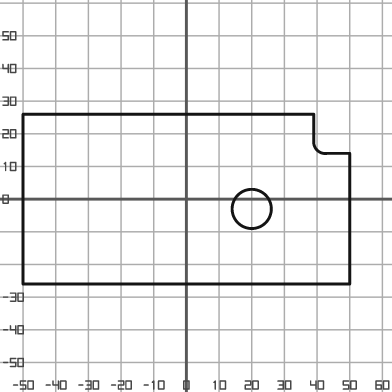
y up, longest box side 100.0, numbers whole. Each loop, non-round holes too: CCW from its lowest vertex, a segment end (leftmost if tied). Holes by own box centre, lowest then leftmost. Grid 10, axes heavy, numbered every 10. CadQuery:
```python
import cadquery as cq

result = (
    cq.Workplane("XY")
    .moveTo(-50.0, -26.0)
    .lineTo(50.0, -26.0)
    .lineTo(50.0, 14.0)
    .lineTo(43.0, 14.0)
    .threePointArc((40.0, 15.0), (39.0, 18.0))
    .lineTo(39.0, 26.0)
    .lineTo(-50.0, 26.0)
    .close()
    .moveTo(20.0, -3.0)
    .circle(6.0)
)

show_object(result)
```